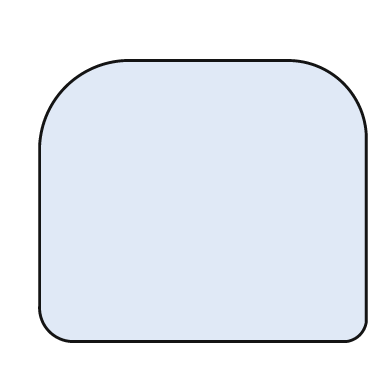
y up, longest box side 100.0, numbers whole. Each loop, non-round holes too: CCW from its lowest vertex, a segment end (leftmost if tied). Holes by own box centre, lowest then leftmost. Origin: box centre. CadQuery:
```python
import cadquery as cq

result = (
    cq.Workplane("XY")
    .moveTo(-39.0, -43.0)
    .lineTo(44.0, -43.0)
    .threePointArc((48.0, -41.0), (50.0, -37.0))
    .lineTo(50.0, 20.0)
    .threePointArc((43.0, 36.0), (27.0, 43.0))
    .lineTo(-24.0, 43.0)
    .threePointArc((-42.0, 35.0), (-50.0, 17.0))
    .lineTo(-50.0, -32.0)
    .threePointArc((-47.0, -40.0), (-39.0, -43.0))
    .close()
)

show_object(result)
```